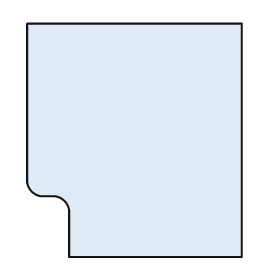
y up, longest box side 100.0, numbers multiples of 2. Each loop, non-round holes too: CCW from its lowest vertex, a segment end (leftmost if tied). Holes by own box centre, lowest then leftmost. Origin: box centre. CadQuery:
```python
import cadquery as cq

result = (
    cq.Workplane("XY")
    .moveTo(-28.0, -50.0)
    .lineTo(46.0, -50.0)
    .lineTo(46.0, 50.0)
    .lineTo(-46.0, 50.0)
    .lineTo(-46.0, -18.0)
    .threePointArc((-44.0, -22.0), (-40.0, -24.0))
    .lineTo(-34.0, -24.0)
    .threePointArc((-30.0, -26.0), (-28.0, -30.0))
    .close()
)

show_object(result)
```